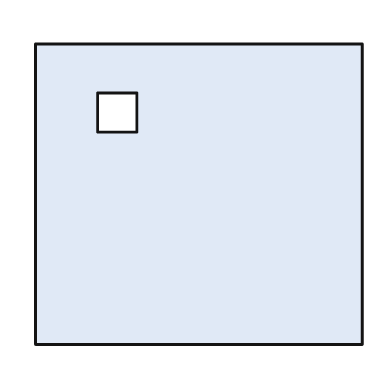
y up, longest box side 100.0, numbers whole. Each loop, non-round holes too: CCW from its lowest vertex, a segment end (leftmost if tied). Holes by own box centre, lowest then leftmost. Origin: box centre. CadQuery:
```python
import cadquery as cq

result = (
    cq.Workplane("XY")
    .moveTo(-50.0, -46.0)
    .lineTo(50.0, -46.0)
    .lineTo(50.0, 46.0)
    .lineTo(-50.0, 46.0)
    .close()
    .moveTo(-31.0, 19.0)
    .lineTo(-19.0, 19.0)
    .lineTo(-19.0, 31.0)
    .lineTo(-31.0, 31.0)
    .close()
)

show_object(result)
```